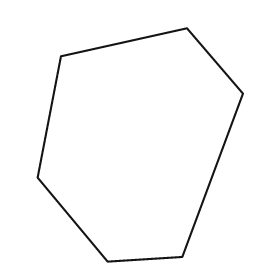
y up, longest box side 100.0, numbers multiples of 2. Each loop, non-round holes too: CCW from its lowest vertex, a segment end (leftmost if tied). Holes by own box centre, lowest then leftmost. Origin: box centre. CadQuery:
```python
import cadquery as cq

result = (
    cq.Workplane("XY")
    .moveTo(-14.0, -50.0)
    .lineTo(18.0, -48.0)
    .lineTo(44.0, 22.0)
    .lineTo(20.0, 50.0)
    .lineTo(-34.0, 38.0)
    .lineTo(-44.0, -14.0)
    .close()
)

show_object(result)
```